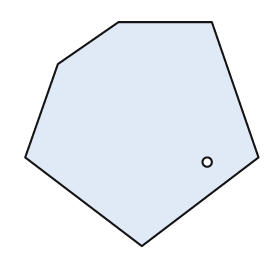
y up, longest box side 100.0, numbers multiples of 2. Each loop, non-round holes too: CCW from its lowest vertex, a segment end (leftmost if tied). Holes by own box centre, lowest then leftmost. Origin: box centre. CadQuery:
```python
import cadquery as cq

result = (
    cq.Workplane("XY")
    .moveTo(0.0, -48.0)
    .lineTo(50.0, -10.0)
    .lineTo(30.0, 48.0)
    .lineTo(-10.0, 48.0)
    .lineTo(-36.0, 30.0)
    .lineTo(-50.0, -10.0)
    .close()
    .moveTo(28.0, -12.0)
    .circle(2.0)
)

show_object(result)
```